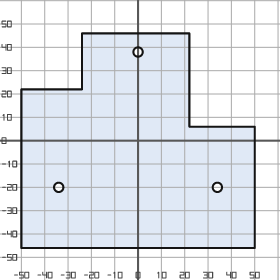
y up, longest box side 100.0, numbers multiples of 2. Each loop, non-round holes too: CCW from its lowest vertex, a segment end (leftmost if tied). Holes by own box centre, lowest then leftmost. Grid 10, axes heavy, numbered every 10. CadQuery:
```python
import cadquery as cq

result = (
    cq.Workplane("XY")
    .moveTo(-50.0, -46.0)
    .lineTo(50.0, -46.0)
    .lineTo(50.0, 6.0)
    .lineTo(22.0, 6.0)
    .lineTo(22.0, 46.0)
    .lineTo(-24.0, 46.0)
    .lineTo(-24.0, 22.0)
    .lineTo(-50.0, 22.0)
    .close()
    .moveTo(-34.0, -20.0)
    .circle(2.0)
    .moveTo(34.0, -20.0)
    .circle(2.0)
    .moveTo(0.0, 38.0)
    .circle(2.0)
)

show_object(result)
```